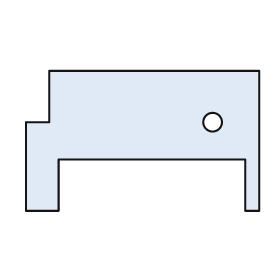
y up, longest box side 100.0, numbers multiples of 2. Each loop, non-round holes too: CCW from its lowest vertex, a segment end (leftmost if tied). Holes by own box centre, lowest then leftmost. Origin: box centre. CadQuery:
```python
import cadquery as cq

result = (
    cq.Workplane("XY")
    .moveTo(-50.0, -30.0)
    .lineTo(-36.0, -30.0)
    .lineTo(-36.0, -8.0)
    .lineTo(44.0, -8.0)
    .lineTo(44.0, -30.0)
    .lineTo(50.0, -30.0)
    .lineTo(50.0, 30.0)
    .lineTo(-40.0, 30.0)
    .lineTo(-40.0, 8.0)
    .lineTo(-50.0, 8.0)
    .close()
    .moveTo(30.0, 8.0)
    .circle(4.0)
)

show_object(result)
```